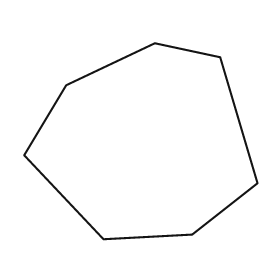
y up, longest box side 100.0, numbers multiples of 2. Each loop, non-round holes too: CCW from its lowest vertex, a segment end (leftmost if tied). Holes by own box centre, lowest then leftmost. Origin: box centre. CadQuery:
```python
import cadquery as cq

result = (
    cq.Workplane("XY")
    .moveTo(-16.0, -42.0)
    .lineTo(22.0, -40.0)
    .lineTo(50.0, -18.0)
    .lineTo(34.0, 36.0)
    .lineTo(6.0, 42.0)
    .lineTo(-32.0, 24.0)
    .lineTo(-50.0, -6.0)
    .close()
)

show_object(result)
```